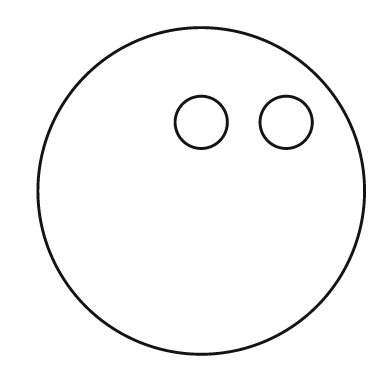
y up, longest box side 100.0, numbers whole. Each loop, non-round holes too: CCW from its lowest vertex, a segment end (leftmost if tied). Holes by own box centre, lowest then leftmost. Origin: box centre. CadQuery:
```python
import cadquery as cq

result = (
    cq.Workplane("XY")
    .moveTo(0.0, 0.0)
    .circle(50.0)
    .moveTo(0.0, 21.0)
    .circle(8.0)
    .moveTo(26.0, 21.0)
    .circle(8.0)
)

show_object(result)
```